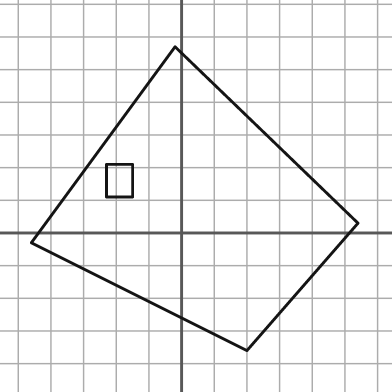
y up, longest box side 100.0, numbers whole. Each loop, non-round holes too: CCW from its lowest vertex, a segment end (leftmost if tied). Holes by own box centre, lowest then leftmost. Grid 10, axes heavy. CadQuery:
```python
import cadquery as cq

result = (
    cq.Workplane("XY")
    .moveTo(20.0, -36.0)
    .lineTo(54.0, 3.0)
    .lineTo(-2.0, 57.0)
    .lineTo(-46.0, -3.0)
    .close()
    .moveTo(-23.0, 11.0)
    .lineTo(-15.0, 11.0)
    .lineTo(-15.0, 21.0)
    .lineTo(-23.0, 21.0)
    .close()
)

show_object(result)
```